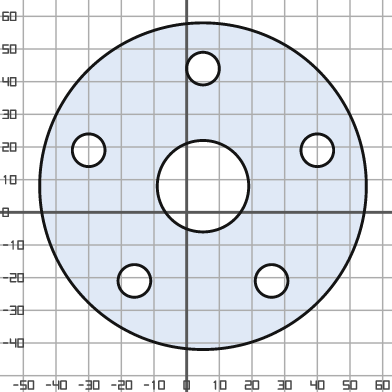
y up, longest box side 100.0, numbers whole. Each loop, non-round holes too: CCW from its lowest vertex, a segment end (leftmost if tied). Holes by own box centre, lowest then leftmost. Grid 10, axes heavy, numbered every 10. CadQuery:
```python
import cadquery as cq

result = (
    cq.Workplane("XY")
    .moveTo(5.0, 8.0)
    .circle(50.0)
    .moveTo(-16.0, -21.0)
    .circle(5.0)
    .moveTo(26.0, -21.0)
    .circle(5.0)
    .moveTo(5.0, 8.0)
    .circle(14.0)
    .moveTo(-30.0, 19.0)
    .circle(5.0)
    .moveTo(40.0, 19.0)
    .circle(5.0)
    .moveTo(5.0, 44.0)
    .circle(5.0)
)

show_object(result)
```